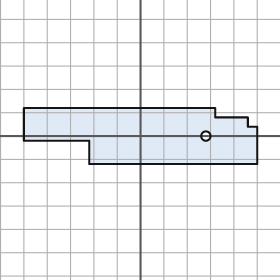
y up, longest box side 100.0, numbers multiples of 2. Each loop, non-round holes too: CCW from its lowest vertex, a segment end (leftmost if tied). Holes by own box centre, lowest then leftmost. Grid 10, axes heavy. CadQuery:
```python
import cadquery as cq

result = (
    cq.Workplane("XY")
    .moveTo(-22.0, -12.0)
    .lineTo(50.0, -12.0)
    .lineTo(50.0, 4.0)
    .lineTo(46.0, 4.0)
    .lineTo(46.0, 8.0)
    .lineTo(32.0, 8.0)
    .lineTo(32.0, 12.0)
    .lineTo(-50.0, 12.0)
    .lineTo(-50.0, -2.0)
    .lineTo(-22.0, -2.0)
    .close()
    .moveTo(28.0, 0.0)
    .circle(2.0)
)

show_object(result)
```